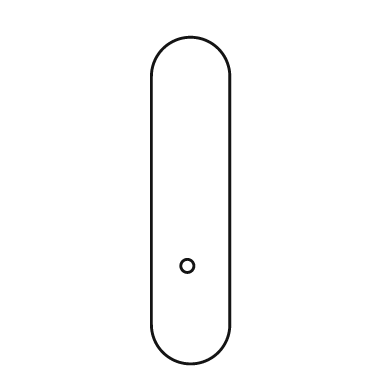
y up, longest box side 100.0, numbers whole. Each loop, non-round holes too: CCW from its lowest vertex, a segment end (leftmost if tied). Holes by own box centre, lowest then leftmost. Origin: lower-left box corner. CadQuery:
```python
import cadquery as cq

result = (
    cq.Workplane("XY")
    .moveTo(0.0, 12.0)
    .threePointArc((12.0, 0.0), (24.0, 12.0))
    .lineTo(24.0, 88.0)
    .threePointArc((12.0, 100.0), (0.0, 88.0))
    .close()
    .moveTo(11.0, 30.0)
    .circle(2.0)
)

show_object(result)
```